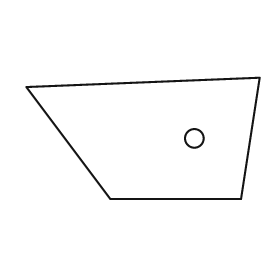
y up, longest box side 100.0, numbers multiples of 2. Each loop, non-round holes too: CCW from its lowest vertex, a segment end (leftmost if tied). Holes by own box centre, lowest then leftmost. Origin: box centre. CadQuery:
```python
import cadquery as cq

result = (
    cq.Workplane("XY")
    .moveTo(-14.0, -26.0)
    .lineTo(42.0, -26.0)
    .lineTo(50.0, 26.0)
    .lineTo(-50.0, 22.0)
    .close()
    .moveTo(22.0, 0.0)
    .circle(4.0)
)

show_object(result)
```